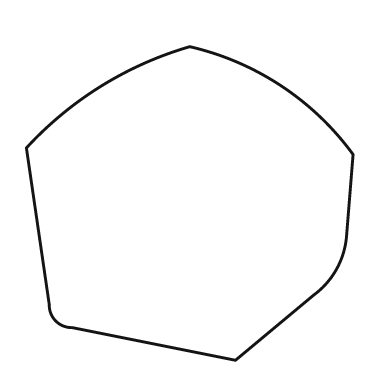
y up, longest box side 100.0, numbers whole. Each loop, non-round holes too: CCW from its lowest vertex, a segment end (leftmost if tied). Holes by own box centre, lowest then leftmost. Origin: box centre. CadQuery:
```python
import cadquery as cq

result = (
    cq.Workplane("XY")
    .moveTo(14.0, -48.0)
    .lineTo(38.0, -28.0)
    .threePointArc((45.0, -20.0), (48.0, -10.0))
    .lineTo(50.0, 15.0)
    .threePointArc((28.0, 36.0), (0.0, 48.0))
    .threePointArc((-27.0, 36.0), (-50.0, 17.0))
    .lineTo(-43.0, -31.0)
    .threePointArc((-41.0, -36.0), (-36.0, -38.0))
    .close()
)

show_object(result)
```